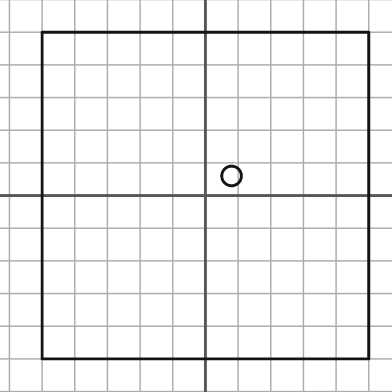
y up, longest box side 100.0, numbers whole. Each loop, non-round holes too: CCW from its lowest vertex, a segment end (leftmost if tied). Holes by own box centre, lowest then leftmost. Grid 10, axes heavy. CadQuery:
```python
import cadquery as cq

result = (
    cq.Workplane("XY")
    .moveTo(-50.0, -50.0)
    .lineTo(50.0, -50.0)
    .lineTo(50.0, 50.0)
    .lineTo(-50.0, 50.0)
    .close()
    .moveTo(8.0, 6.0)
    .circle(3.0)
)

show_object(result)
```